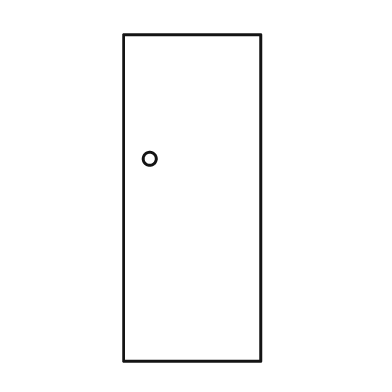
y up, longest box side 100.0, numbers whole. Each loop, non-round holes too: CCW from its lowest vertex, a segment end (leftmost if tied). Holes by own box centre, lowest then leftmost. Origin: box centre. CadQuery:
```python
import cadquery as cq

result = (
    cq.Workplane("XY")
    .moveTo(-21.0, -50.0)
    .lineTo(21.0, -50.0)
    .lineTo(21.0, 50.0)
    .lineTo(-21.0, 50.0)
    .close()
    .moveTo(-13.0, 12.0)
    .circle(2.0)
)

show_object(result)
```